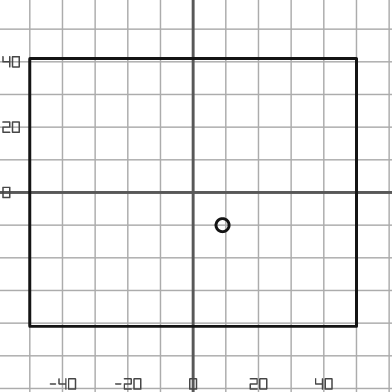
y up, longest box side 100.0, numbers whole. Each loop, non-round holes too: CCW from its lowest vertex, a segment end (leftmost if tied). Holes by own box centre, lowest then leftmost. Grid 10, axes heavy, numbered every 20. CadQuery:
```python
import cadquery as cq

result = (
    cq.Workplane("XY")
    .moveTo(-50.0, -41.0)
    .lineTo(50.0, -41.0)
    .lineTo(50.0, 41.0)
    .lineTo(-50.0, 41.0)
    .close()
    .moveTo(9.0, -10.0)
    .circle(2.0)
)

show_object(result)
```